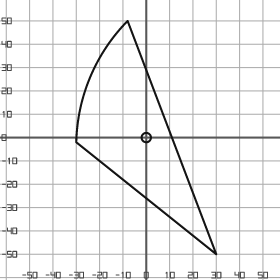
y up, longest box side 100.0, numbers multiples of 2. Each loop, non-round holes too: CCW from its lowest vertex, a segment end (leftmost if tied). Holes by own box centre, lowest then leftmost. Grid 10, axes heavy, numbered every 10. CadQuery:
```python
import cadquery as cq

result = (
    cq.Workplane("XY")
    .moveTo(30.0, -50.0)
    .lineTo(-8.0, 50.0)
    .threePointArc((-24.0, 26.0), (-30.0, -2.0))
    .close()
    .moveTo(0.0, 0.0)
    .circle(2.0)
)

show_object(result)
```